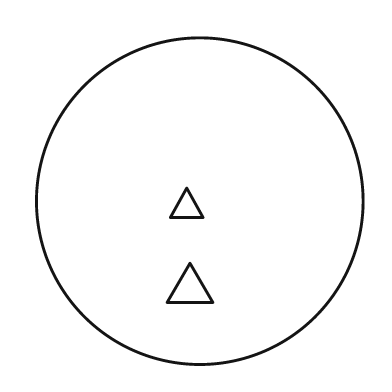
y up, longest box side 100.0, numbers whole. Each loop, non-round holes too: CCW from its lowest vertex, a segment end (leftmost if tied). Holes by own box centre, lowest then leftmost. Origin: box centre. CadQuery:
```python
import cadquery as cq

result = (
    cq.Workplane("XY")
    .moveTo(0.0, 0.0)
    .circle(50.0)
    .moveTo(-10.0, -31.0)
    .lineTo(4.0, -31.0)
    .lineTo(-3.0, -19.0)
    .close()
    .moveTo(-9.0, -5.0)
    .lineTo(1.0, -5.0)
    .lineTo(-4.0, 4.0)
    .close()
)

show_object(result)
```